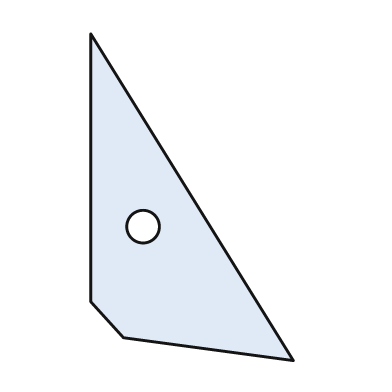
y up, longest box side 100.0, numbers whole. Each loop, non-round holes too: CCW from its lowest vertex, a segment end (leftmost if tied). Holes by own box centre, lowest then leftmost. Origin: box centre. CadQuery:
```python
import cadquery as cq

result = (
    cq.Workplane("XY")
    .moveTo(31.0, -50.0)
    .lineTo(-31.0, 50.0)
    .lineTo(-31.0, -32.0)
    .lineTo(-21.0, -43.0)
    .close()
    .moveTo(-15.0, -9.0)
    .circle(5.0)
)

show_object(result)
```